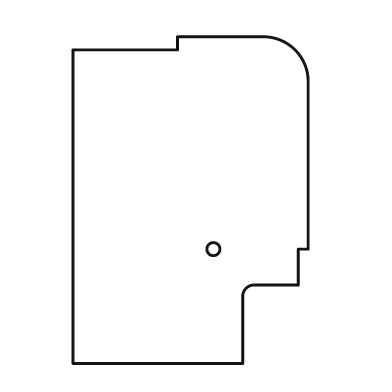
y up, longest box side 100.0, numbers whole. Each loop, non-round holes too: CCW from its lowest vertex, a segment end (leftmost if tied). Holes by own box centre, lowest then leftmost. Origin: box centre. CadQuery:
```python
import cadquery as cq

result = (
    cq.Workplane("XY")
    .moveTo(-36.0, -50.0)
    .lineTo(16.0, -50.0)
    .lineTo(16.0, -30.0)
    .threePointArc((17.0, -27.0), (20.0, -26.0))
    .lineTo(33.0, -26.0)
    .lineTo(33.0, -15.0)
    .lineTo(36.0, -15.0)
    .lineTo(36.0, 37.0)
    .threePointArc((32.0, 46.0), (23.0, 50.0))
    .lineTo(-4.0, 50.0)
    .lineTo(-4.0, 46.0)
    .lineTo(-36.0, 46.0)
    .close()
    .moveTo(7.0, -15.0)
    .circle(2.0)
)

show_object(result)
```